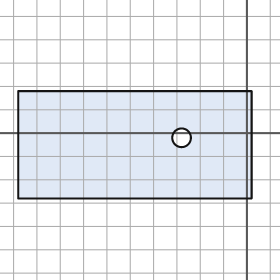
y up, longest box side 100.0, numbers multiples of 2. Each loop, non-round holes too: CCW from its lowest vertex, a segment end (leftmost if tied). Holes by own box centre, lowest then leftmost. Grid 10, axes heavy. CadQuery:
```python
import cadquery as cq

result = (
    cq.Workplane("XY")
    .moveTo(-98.0, -28.0)
    .lineTo(2.0, -28.0)
    .lineTo(2.0, 18.0)
    .lineTo(-98.0, 18.0)
    .close()
    .moveTo(-28.0, -2.0)
    .circle(4.0)
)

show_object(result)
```